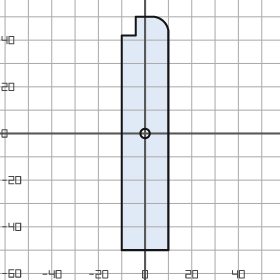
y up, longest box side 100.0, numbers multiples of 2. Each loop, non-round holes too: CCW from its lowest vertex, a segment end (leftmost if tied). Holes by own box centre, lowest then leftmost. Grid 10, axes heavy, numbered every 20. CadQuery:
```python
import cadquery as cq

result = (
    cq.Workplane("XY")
    .moveTo(-10.0, -50.0)
    .lineTo(10.0, -50.0)
    .lineTo(10.0, 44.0)
    .threePointArc((8.0, 48.0), (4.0, 50.0))
    .lineTo(-4.0, 50.0)
    .lineTo(-4.0, 42.0)
    .lineTo(-10.0, 42.0)
    .close()
    .moveTo(0.0, 0.0)
    .circle(2.0)
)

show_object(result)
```